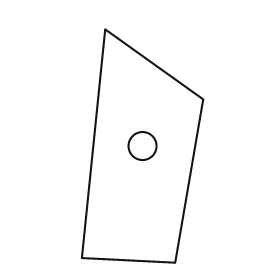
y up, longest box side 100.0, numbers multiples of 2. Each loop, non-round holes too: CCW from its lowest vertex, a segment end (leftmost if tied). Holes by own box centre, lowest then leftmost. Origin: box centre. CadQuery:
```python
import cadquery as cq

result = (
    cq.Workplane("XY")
    .moveTo(14.0, -50.0)
    .lineTo(26.0, 20.0)
    .lineTo(-16.0, 50.0)
    .lineTo(-26.0, -48.0)
    .close()
    .moveTo(0.0, 0.0)
    .circle(6.0)
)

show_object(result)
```